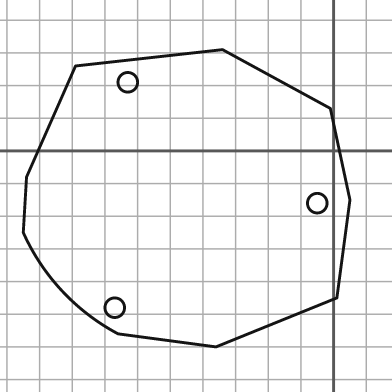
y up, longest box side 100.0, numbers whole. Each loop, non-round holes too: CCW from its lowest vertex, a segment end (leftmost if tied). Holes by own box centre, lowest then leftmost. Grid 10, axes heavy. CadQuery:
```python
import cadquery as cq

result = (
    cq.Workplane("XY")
    .moveTo(-36.0, -60.0)
    .lineTo(1.0, -45.0)
    .lineTo(5.0, -15.0)
    .lineTo(-1.0, 13.0)
    .lineTo(-34.0, 31.0)
    .lineTo(-79.0, 26.0)
    .lineTo(-94.0, -8.0)
    .lineTo(-95.0, -25.0)
    .threePointArc((-83.0, -43.0), (-66.0, -56.0))
    .close()
    .moveTo(-67.0, -48.0)
    .circle(3.0)
    .moveTo(-5.0, -16.0)
    .circle(3.0)
    .moveTo(-63.0, 21.0)
    .circle(3.0)
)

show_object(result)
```